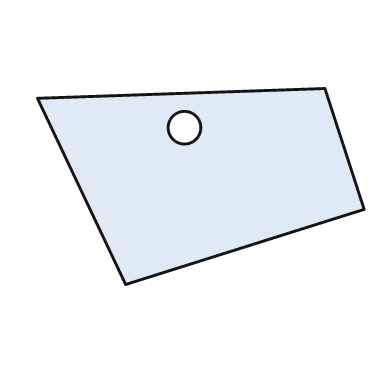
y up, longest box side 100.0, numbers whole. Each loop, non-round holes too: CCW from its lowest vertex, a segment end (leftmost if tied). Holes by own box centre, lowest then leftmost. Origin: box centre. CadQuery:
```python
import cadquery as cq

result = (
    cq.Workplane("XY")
    .moveTo(-23.0, -30.0)
    .lineTo(50.0, -7.0)
    .lineTo(38.0, 30.0)
    .lineTo(-50.0, 27.0)
    .close()
    .moveTo(-5.0, 18.0)
    .circle(5.0)
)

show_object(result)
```